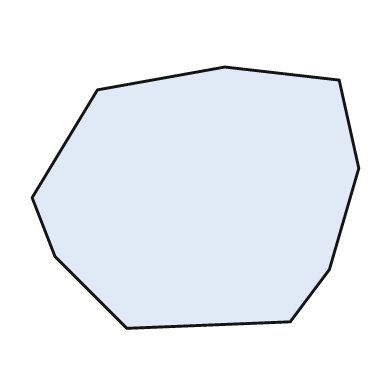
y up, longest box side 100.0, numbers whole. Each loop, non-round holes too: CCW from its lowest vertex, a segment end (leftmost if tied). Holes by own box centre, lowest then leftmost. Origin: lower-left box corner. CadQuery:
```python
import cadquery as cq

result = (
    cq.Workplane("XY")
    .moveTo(29.0, 0.0)
    .lineTo(79.0, 2.0)
    .lineTo(91.0, 18.0)
    .lineTo(100.0, 49.0)
    .lineTo(94.0, 76.0)
    .lineTo(59.0, 80.0)
    .lineTo(20.0, 73.0)
    .lineTo(0.0, 40.0)
    .lineTo(7.0, 22.0)
    .close()
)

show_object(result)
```